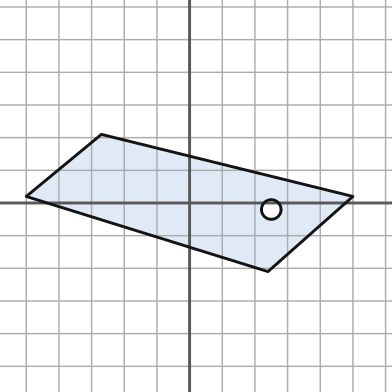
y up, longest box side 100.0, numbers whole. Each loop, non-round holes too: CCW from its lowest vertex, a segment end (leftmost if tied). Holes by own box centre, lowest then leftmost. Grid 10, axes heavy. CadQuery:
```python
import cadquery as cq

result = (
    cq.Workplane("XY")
    .moveTo(24.0, -21.0)
    .lineTo(50.0, 2.0)
    .lineTo(-27.0, 21.0)
    .lineTo(-50.0, 2.0)
    .close()
    .moveTo(25.0, -2.0)
    .circle(3.0)
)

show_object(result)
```